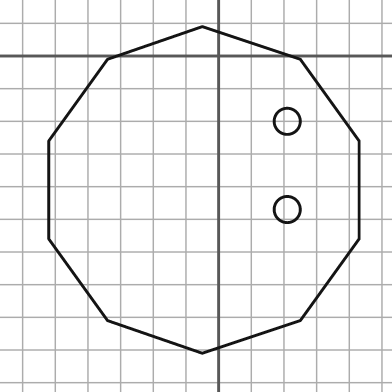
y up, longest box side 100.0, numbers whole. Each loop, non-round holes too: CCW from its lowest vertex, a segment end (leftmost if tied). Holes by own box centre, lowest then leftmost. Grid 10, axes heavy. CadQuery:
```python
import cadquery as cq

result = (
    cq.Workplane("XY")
    .moveTo(-5.0, -91.0)
    .lineTo(25.0, -81.0)
    .lineTo(43.0, -56.0)
    .lineTo(43.0, -26.0)
    .lineTo(25.0, -1.0)
    .lineTo(-5.0, 9.0)
    .lineTo(-34.0, -1.0)
    .lineTo(-52.0, -26.0)
    .lineTo(-52.0, -56.0)
    .lineTo(-34.0, -81.0)
    .close()
    .moveTo(21.0, -47.0)
    .circle(4.0)
    .moveTo(21.0, -20.0)
    .circle(4.0)
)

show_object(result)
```